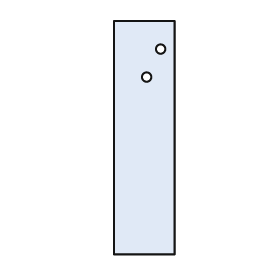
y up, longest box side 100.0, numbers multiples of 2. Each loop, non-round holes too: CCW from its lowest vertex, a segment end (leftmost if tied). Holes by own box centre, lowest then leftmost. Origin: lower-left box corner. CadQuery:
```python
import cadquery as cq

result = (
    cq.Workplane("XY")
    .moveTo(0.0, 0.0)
    .lineTo(26.0, 0.0)
    .lineTo(26.0, 100.0)
    .lineTo(0.0, 100.0)
    .close()
    .moveTo(14.0, 76.0)
    .circle(2.0)
    .moveTo(20.0, 88.0)
    .circle(2.0)
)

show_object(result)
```